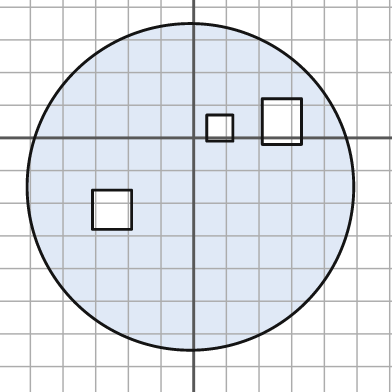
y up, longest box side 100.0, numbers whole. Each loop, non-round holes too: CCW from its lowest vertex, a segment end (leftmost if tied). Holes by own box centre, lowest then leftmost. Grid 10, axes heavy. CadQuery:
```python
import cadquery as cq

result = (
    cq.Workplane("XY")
    .moveTo(-1.0, -15.0)
    .circle(50.0)
    .moveTo(-31.0, -28.0)
    .lineTo(-19.0, -28.0)
    .lineTo(-19.0, -16.0)
    .lineTo(-31.0, -16.0)
    .close()
    .moveTo(4.0, -1.0)
    .lineTo(12.0, -1.0)
    .lineTo(12.0, 7.0)
    .lineTo(4.0, 7.0)
    .close()
    .moveTo(21.0, -2.0)
    .lineTo(33.0, -2.0)
    .lineTo(33.0, 12.0)
    .lineTo(21.0, 12.0)
    .close()
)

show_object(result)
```